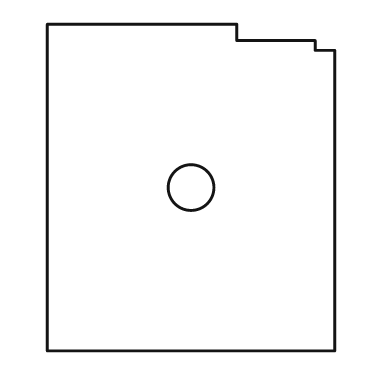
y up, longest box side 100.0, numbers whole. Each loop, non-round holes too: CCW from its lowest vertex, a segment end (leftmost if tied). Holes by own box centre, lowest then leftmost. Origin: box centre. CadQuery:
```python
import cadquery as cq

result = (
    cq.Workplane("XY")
    .moveTo(-44.0, -50.0)
    .lineTo(44.0, -50.0)
    .lineTo(44.0, 42.0)
    .lineTo(38.0, 42.0)
    .lineTo(38.0, 45.0)
    .lineTo(14.0, 45.0)
    .lineTo(14.0, 50.0)
    .lineTo(-44.0, 50.0)
    .close()
    .moveTo(0.0, 0.0)
    .circle(7.0)
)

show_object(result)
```